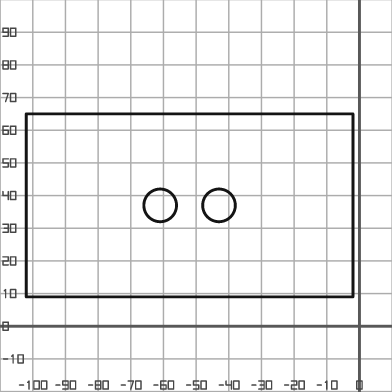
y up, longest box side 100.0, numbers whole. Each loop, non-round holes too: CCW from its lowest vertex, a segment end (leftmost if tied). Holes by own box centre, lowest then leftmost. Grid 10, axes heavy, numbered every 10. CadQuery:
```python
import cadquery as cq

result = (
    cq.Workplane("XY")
    .moveTo(-102.0, 9.0)
    .lineTo(-2.0, 9.0)
    .lineTo(-2.0, 65.0)
    .lineTo(-102.0, 65.0)
    .close()
    .moveTo(-61.0, 37.0)
    .circle(5.0)
    .moveTo(-43.0, 37.0)
    .circle(5.0)
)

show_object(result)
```